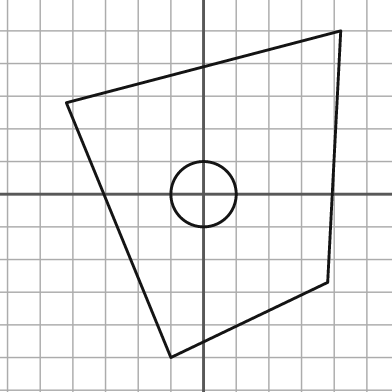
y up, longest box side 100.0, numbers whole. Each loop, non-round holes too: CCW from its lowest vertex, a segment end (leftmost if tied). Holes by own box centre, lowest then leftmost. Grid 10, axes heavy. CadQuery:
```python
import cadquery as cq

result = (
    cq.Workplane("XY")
    .moveTo(-10.0, -50.0)
    .lineTo(38.0, -27.0)
    .lineTo(42.0, 50.0)
    .lineTo(-42.0, 28.0)
    .close()
    .moveTo(0.0, 0.0)
    .circle(10.0)
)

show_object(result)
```